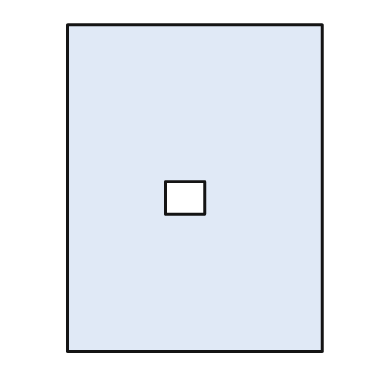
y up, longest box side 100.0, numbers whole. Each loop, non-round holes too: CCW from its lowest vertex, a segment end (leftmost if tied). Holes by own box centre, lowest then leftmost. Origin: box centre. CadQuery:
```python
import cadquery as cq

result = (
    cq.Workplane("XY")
    .moveTo(-39.0, -50.0)
    .lineTo(39.0, -50.0)
    .lineTo(39.0, 50.0)
    .lineTo(-39.0, 50.0)
    .close()
    .moveTo(-9.0, -8.0)
    .lineTo(3.0, -8.0)
    .lineTo(3.0, 2.0)
    .lineTo(-9.0, 2.0)
    .close()
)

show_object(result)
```